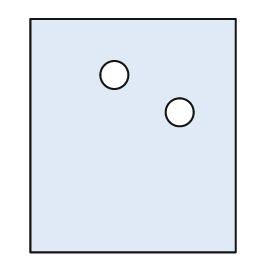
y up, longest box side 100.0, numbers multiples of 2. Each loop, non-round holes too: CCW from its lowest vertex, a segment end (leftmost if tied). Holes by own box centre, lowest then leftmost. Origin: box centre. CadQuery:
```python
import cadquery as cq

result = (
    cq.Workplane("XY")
    .moveTo(-44.0, -50.0)
    .lineTo(44.0, -50.0)
    .lineTo(44.0, 50.0)
    .lineTo(-44.0, 50.0)
    .close()
    .moveTo(20.0, 10.0)
    .circle(6.0)
    .moveTo(-8.0, 26.0)
    .circle(6.0)
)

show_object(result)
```